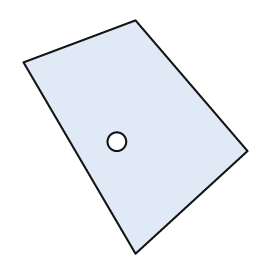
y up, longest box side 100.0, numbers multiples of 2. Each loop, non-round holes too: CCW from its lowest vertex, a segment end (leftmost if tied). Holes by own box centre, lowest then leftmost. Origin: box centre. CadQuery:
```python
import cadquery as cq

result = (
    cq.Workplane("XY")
    .moveTo(0.0, -50.0)
    .lineTo(48.0, -6.0)
    .lineTo(0.0, 50.0)
    .lineTo(-48.0, 32.0)
    .close()
    .moveTo(-8.0, -2.0)
    .circle(4.0)
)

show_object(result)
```